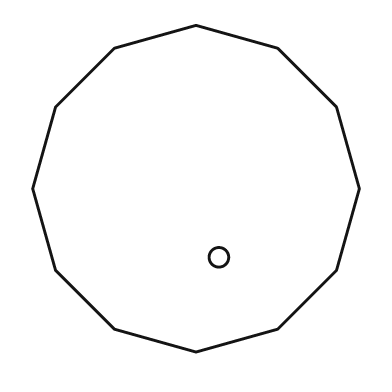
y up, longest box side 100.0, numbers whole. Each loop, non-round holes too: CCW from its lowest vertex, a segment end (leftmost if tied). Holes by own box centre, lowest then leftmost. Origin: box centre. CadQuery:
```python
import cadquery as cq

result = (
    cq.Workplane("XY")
    .moveTo(0.0, -50.0)
    .lineTo(25.0, -43.0)
    .lineTo(43.0, -25.0)
    .lineTo(50.0, 0.0)
    .lineTo(43.0, 25.0)
    .lineTo(25.0, 43.0)
    .lineTo(0.0, 50.0)
    .lineTo(-25.0, 43.0)
    .lineTo(-43.0, 25.0)
    .lineTo(-50.0, 0.0)
    .lineTo(-43.0, -25.0)
    .lineTo(-25.0, -43.0)
    .close()
    .moveTo(7.0, -21.0)
    .circle(3.0)
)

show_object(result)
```